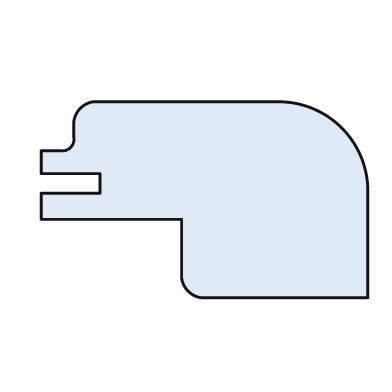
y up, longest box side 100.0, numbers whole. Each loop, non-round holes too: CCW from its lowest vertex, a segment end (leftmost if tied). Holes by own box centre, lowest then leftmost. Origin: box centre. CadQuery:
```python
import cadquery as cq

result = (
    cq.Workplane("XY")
    .moveTo(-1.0, -30.0)
    .lineTo(50.0, -30.0)
    .lineTo(50.0, 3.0)
    .threePointArc((42.0, 22.0), (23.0, 30.0))
    .lineTo(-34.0, 30.0)
    .threePointArc((-38.0, 28.0), (-40.0, 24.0))
    .lineTo(-40.0, 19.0)
    .threePointArc((-41.0, 16.0), (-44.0, 15.0))
    .lineTo(-50.0, 15.0)
    .lineTo(-50.0, 8.0)
    .lineTo(-32.0, 8.0)
    .lineTo(-32.0, 2.0)
    .lineTo(-50.0, 2.0)
    .lineTo(-50.0, -6.0)
    .lineTo(-7.0, -6.0)
    .lineTo(-7.0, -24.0)
    .threePointArc((-5.0, -28.0), (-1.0, -30.0))
    .close()
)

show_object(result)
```